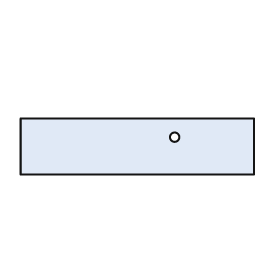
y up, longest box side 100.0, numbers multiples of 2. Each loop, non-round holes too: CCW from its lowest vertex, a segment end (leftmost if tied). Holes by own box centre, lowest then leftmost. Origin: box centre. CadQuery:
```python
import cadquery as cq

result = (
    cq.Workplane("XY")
    .moveTo(-50.0, -12.0)
    .lineTo(50.0, -12.0)
    .lineTo(50.0, 12.0)
    .lineTo(-50.0, 12.0)
    .close()
    .moveTo(16.0, 4.0)
    .circle(2.0)
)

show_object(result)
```